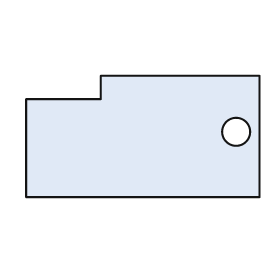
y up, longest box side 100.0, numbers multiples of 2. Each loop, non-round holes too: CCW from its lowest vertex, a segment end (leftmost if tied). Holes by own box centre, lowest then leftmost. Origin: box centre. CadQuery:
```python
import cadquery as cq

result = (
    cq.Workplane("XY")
    .moveTo(-50.0, -26.0)
    .lineTo(50.0, -26.0)
    .lineTo(50.0, 26.0)
    .lineTo(-18.0, 26.0)
    .lineTo(-18.0, 16.0)
    .lineTo(-50.0, 16.0)
    .close()
    .moveTo(40.0, 2.0)
    .circle(6.0)
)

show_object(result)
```